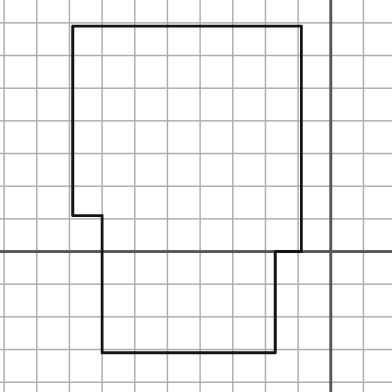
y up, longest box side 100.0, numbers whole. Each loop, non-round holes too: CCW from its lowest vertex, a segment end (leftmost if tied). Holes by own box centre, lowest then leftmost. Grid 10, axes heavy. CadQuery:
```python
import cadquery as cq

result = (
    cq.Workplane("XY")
    .moveTo(-70.0, -31.0)
    .lineTo(-17.0, -31.0)
    .lineTo(-17.0, 0.0)
    .lineTo(-9.0, 0.0)
    .lineTo(-9.0, 69.0)
    .lineTo(-79.0, 69.0)
    .lineTo(-79.0, 11.0)
    .lineTo(-70.0, 11.0)
    .close()
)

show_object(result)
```